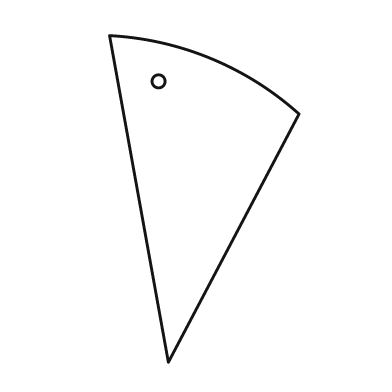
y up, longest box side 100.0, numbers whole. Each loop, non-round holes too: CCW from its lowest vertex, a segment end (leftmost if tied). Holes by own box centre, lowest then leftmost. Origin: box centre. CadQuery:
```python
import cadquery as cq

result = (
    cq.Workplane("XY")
    .moveTo(-11.0, -50.0)
    .lineTo(29.0, 26.0)
    .threePointArc((2.0, 43.0), (-29.0, 50.0))
    .close()
    .moveTo(-14.0, 36.0)
    .circle(2.0)
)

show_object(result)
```